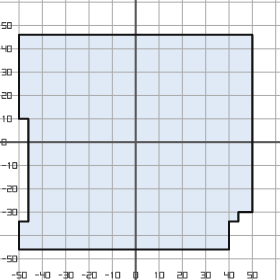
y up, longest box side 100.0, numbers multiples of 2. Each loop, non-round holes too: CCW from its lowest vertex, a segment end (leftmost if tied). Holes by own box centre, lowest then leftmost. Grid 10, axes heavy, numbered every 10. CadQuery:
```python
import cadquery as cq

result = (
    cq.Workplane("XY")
    .moveTo(-50.0, -46.0)
    .lineTo(40.0, -46.0)
    .lineTo(40.0, -34.0)
    .lineTo(44.0, -34.0)
    .lineTo(44.0, -30.0)
    .lineTo(50.0, -30.0)
    .lineTo(50.0, 46.0)
    .lineTo(-50.0, 46.0)
    .lineTo(-50.0, 10.0)
    .lineTo(-46.0, 10.0)
    .lineTo(-46.0, -34.0)
    .lineTo(-50.0, -34.0)
    .close()
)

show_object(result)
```